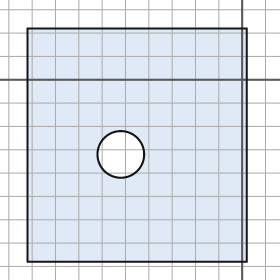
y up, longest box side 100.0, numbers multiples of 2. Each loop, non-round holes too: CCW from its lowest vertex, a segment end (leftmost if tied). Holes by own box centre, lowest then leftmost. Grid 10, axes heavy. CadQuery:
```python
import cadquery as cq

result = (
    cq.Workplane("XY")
    .moveTo(-92.0, -78.0)
    .lineTo(2.0, -78.0)
    .lineTo(2.0, 22.0)
    .lineTo(-92.0, 22.0)
    .close()
    .moveTo(-52.0, -32.0)
    .circle(10.0)
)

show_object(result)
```